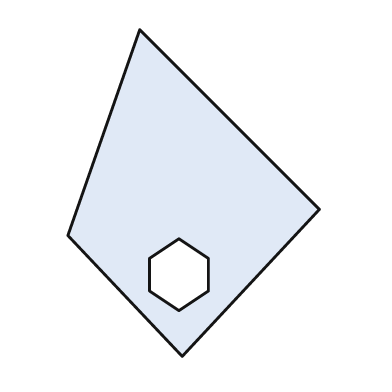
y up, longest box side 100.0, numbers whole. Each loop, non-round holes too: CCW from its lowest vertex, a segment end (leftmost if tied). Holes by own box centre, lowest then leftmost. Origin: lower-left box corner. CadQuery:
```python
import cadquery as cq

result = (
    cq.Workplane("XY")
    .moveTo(35.0, 0.0)
    .lineTo(77.0, 45.0)
    .lineTo(22.0, 100.0)
    .lineTo(0.0, 37.0)
    .close()
    .moveTo(34.0, 14.0)
    .lineTo(43.0, 20.0)
    .lineTo(43.0, 30.0)
    .lineTo(34.0, 36.0)
    .lineTo(25.0, 30.0)
    .lineTo(25.0, 20.0)
    .close()
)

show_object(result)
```